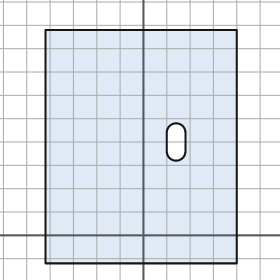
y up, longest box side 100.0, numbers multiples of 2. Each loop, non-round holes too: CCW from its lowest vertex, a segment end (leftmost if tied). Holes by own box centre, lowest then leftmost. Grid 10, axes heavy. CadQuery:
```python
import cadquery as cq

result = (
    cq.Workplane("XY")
    .moveTo(-42.0, -12.0)
    .lineTo(40.0, -12.0)
    .lineTo(40.0, 88.0)
    .lineTo(-42.0, 88.0)
    .close()
    .moveTo(10.0, 36.0)
    .threePointArc((14.0, 32.0), (18.0, 36.0))
    .lineTo(18.0, 44.0)
    .threePointArc((14.0, 48.0), (10.0, 44.0))
    .close()
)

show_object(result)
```